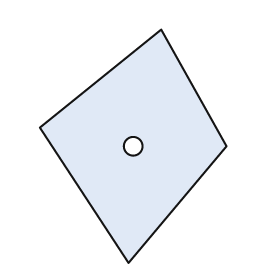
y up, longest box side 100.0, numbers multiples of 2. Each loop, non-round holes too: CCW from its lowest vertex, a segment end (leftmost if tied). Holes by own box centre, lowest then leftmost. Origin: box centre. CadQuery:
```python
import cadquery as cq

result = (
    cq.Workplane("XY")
    .moveTo(-2.0, -50.0)
    .lineTo(40.0, 0.0)
    .lineTo(12.0, 50.0)
    .lineTo(-40.0, 8.0)
    .close()
    .moveTo(0.0, 0.0)
    .circle(4.0)
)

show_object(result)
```